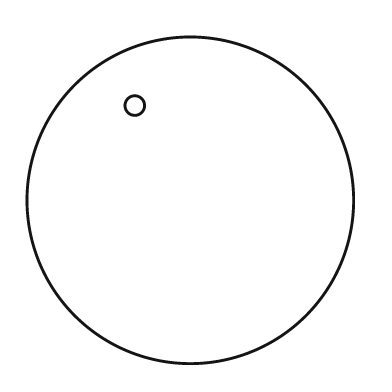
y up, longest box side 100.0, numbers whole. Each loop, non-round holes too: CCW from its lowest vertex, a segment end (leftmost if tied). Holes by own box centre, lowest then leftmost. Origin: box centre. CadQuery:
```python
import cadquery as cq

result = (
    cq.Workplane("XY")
    .moveTo(0.0, 0.0)
    .circle(50.0)
    .moveTo(-17.0, 29.0)
    .circle(3.0)
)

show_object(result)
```